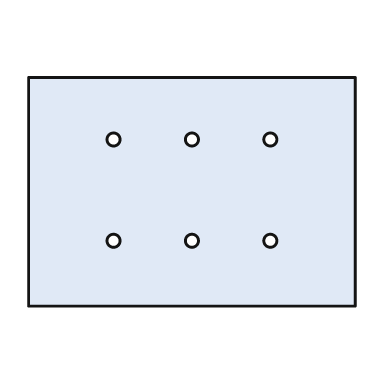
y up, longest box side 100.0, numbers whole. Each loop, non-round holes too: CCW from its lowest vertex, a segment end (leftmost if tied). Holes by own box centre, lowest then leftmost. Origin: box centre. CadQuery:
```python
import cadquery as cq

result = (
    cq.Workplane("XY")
    .moveTo(-50.0, -35.0)
    .lineTo(50.0, -35.0)
    .lineTo(50.0, 35.0)
    .lineTo(-50.0, 35.0)
    .close()
    .moveTo(-24.0, -15.0)
    .circle(2.0)
    .moveTo(0.0, -15.0)
    .circle(2.0)
    .moveTo(24.0, -15.0)
    .circle(2.0)
    .moveTo(-24.0, 16.0)
    .circle(2.0)
    .moveTo(0.0, 16.0)
    .circle(2.0)
    .moveTo(24.0, 16.0)
    .circle(2.0)
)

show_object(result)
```